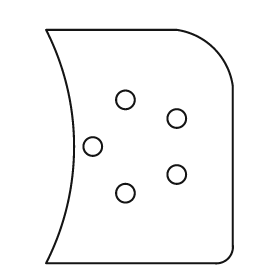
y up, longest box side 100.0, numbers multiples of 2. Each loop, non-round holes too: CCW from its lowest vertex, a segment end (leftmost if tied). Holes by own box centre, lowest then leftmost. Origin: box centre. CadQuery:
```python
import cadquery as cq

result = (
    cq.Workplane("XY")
    .moveTo(-40.0, -50.0)
    .lineTo(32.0, -50.0)
    .threePointArc((38.0, -48.0), (40.0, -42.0))
    .lineTo(40.0, 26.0)
    .threePointArc((32.0, 42.0), (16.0, 50.0))
    .lineTo(-40.0, 50.0)
    .threePointArc((-28.0, 0.0), (-40.0, -50.0))
    .close()
    .moveTo(-6.0, -20.0)
    .circle(4.0)
    .moveTo(16.0, -12.0)
    .circle(4.0)
    .moveTo(-20.0, 0.0)
    .circle(4.0)
    .moveTo(16.0, 12.0)
    .circle(4.0)
    .moveTo(-6.0, 20.0)
    .circle(4.0)
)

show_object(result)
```